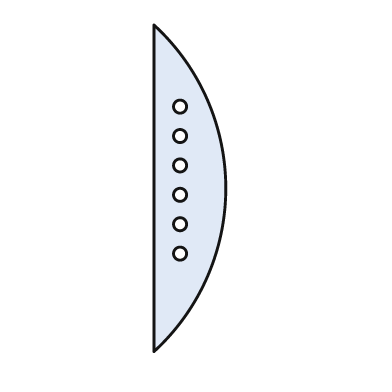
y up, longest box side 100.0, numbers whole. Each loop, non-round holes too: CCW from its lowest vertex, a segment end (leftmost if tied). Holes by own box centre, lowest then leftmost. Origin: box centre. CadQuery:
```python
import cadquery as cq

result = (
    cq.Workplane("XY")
    .moveTo(-11.0, -50.0)
    .threePointArc((11.0, 0.0), (-11.0, 50.0))
    .close()
    .moveTo(-3.0, -20.0)
    .circle(2.0)
    .moveTo(-3.0, -11.0)
    .circle(2.0)
    .moveTo(-3.0, -2.0)
    .circle(2.0)
    .moveTo(-3.0, 7.0)
    .circle(2.0)
    .moveTo(-3.0, 16.0)
    .circle(2.0)
    .moveTo(-3.0, 25.0)
    .circle(2.0)
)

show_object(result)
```